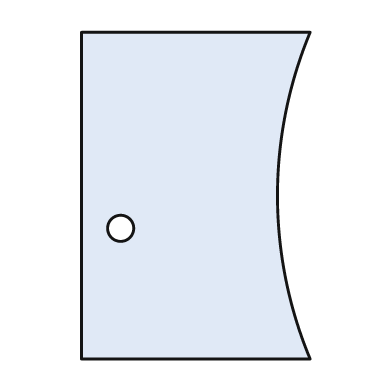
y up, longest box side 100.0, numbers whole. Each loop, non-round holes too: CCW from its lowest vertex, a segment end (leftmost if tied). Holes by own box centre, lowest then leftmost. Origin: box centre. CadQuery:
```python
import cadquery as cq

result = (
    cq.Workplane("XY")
    .moveTo(-35.0, -50.0)
    .lineTo(35.0, -50.0)
    .threePointArc((25.0, 0.0), (35.0, 50.0))
    .lineTo(-35.0, 50.0)
    .close()
    .moveTo(-23.0, -10.0)
    .circle(4.0)
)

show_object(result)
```